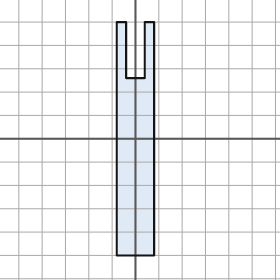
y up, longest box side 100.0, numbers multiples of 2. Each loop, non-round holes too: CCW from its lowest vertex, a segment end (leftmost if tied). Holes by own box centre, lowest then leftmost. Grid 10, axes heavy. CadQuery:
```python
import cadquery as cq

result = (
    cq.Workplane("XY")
    .moveTo(-8.0, -50.0)
    .lineTo(8.0, -50.0)
    .lineTo(8.0, 50.0)
    .lineTo(4.0, 50.0)
    .lineTo(4.0, 26.0)
    .lineTo(-4.0, 26.0)
    .lineTo(-4.0, 50.0)
    .lineTo(-8.0, 50.0)
    .close()
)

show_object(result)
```